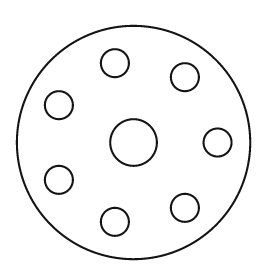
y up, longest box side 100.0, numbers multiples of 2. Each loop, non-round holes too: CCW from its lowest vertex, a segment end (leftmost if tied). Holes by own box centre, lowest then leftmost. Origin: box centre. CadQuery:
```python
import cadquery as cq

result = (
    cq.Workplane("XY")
    .moveTo(0.0, 0.0)
    .circle(50.0)
    .moveTo(-8.0, -34.0)
    .circle(6.0)
    .moveTo(22.0, -28.0)
    .circle(6.0)
    .moveTo(-32.0, -16.0)
    .circle(6.0)
    .moveTo(0.0, 0.0)
    .circle(10.0)
    .moveTo(36.0, 0.0)
    .circle(6.0)
    .moveTo(-32.0, 16.0)
    .circle(6.0)
    .moveTo(22.0, 28.0)
    .circle(6.0)
    .moveTo(-8.0, 34.0)
    .circle(6.0)
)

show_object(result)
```